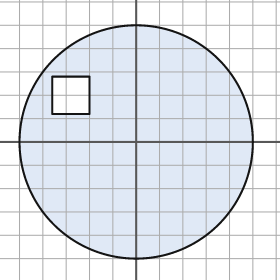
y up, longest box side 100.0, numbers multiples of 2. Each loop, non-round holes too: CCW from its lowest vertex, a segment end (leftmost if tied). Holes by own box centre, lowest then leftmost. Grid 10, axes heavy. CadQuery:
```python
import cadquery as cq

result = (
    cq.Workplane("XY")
    .moveTo(0.0, 0.0)
    .circle(50.0)
    .moveTo(-36.0, 12.0)
    .lineTo(-20.0, 12.0)
    .lineTo(-20.0, 28.0)
    .lineTo(-36.0, 28.0)
    .close()
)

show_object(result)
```